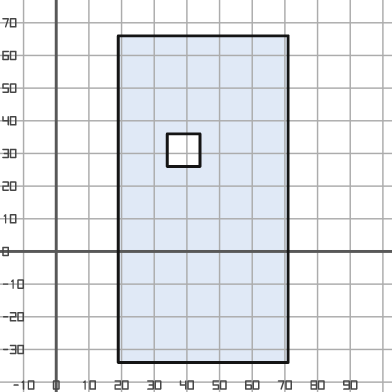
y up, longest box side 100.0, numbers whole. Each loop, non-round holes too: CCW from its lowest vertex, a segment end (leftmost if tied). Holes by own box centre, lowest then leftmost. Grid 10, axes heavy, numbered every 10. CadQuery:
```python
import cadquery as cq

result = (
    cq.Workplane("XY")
    .moveTo(19.0, -34.0)
    .lineTo(71.0, -34.0)
    .lineTo(71.0, 66.0)
    .lineTo(19.0, 66.0)
    .close()
    .moveTo(34.0, 26.0)
    .lineTo(44.0, 26.0)
    .lineTo(44.0, 36.0)
    .lineTo(34.0, 36.0)
    .close()
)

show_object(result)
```